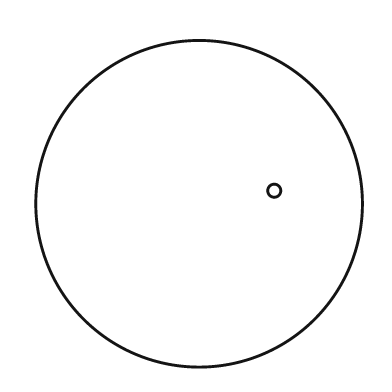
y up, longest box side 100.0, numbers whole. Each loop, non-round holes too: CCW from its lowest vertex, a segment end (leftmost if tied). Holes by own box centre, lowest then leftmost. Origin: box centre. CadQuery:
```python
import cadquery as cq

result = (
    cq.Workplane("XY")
    .moveTo(0.0, 0.0)
    .circle(50.0)
    .moveTo(23.0, 4.0)
    .circle(2.0)
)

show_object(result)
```